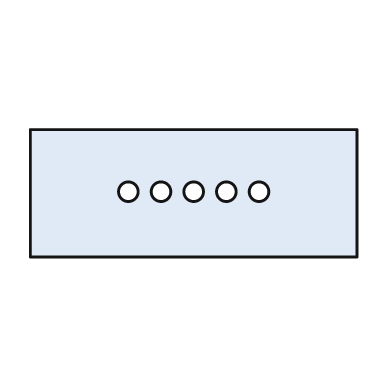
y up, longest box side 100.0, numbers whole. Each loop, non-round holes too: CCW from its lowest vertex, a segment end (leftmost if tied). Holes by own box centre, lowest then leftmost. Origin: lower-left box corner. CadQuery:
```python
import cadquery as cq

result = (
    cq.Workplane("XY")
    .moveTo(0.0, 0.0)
    .lineTo(100.0, 0.0)
    .lineTo(100.0, 39.0)
    .lineTo(0.0, 39.0)
    .close()
    .moveTo(30.0, 20.0)
    .circle(3.0)
    .moveTo(40.0, 20.0)
    .circle(3.0)
    .moveTo(50.0, 20.0)
    .circle(3.0)
    .moveTo(60.0, 20.0)
    .circle(3.0)
    .moveTo(70.0, 20.0)
    .circle(3.0)
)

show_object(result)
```